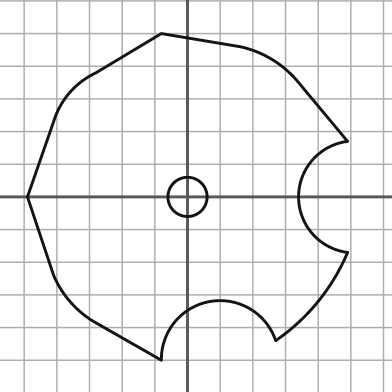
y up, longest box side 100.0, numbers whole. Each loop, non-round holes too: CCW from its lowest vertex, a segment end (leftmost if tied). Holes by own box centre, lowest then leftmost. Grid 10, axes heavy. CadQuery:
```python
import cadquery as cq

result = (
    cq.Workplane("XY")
    .moveTo(-8.0, -50.0)
    .threePointArc((7.0, -32.0), (27.0, -44.0))
    .threePointArc((40.0, -32.0), (49.0, -17.0))
    .threePointArc((34.0, 0.0), (49.0, 17.0))
    .lineTo(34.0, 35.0)
    .threePointArc((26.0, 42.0), (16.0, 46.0))
    .lineTo(-8.0, 50.0)
    .lineTo(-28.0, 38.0)
    .threePointArc((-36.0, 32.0), (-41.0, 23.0))
    .lineTo(-49.0, 0.0)
    .lineTo(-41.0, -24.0)
    .threePointArc((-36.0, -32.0), (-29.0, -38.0))
    .close()
    .moveTo(0.0, 0.0)
    .circle(6.0)
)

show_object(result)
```